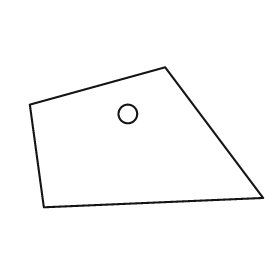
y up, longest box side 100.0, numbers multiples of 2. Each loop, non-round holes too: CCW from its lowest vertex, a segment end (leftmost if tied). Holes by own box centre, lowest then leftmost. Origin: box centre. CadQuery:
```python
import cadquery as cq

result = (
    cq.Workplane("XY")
    .moveTo(-44.0, -30.0)
    .lineTo(50.0, -26.0)
    .lineTo(8.0, 30.0)
    .lineTo(-50.0, 14.0)
    .close()
    .moveTo(-8.0, 10.0)
    .circle(4.0)
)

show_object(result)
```